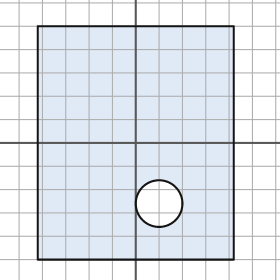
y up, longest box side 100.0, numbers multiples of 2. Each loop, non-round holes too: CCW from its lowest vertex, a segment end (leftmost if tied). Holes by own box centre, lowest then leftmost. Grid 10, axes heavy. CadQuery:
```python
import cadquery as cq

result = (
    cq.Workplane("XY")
    .moveTo(-42.0, -50.0)
    .lineTo(42.0, -50.0)
    .lineTo(42.0, 50.0)
    .lineTo(-42.0, 50.0)
    .close()
    .moveTo(10.0, -26.0)
    .circle(10.0)
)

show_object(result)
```